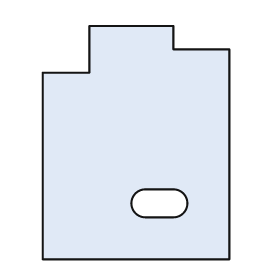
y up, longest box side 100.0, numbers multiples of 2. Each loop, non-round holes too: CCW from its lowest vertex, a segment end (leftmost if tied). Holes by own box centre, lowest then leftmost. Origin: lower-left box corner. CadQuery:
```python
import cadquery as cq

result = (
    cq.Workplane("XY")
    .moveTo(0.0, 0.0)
    .lineTo(80.0, 0.0)
    .lineTo(80.0, 90.0)
    .lineTo(56.0, 90.0)
    .lineTo(56.0, 100.0)
    .lineTo(20.0, 100.0)
    .lineTo(20.0, 80.0)
    .lineTo(0.0, 80.0)
    .close()
    .moveTo(44.0, 18.0)
    .lineTo(56.0, 18.0)
    .threePointArc((62.0, 24.0), (56.0, 30.0))
    .lineTo(44.0, 30.0)
    .threePointArc((38.0, 24.0), (44.0, 18.0))
    .close()
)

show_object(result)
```